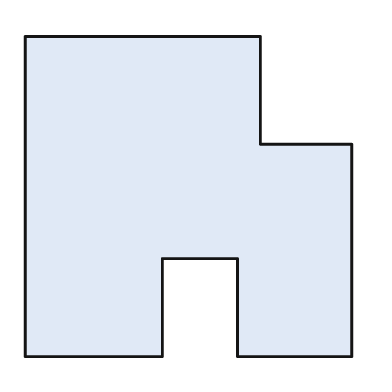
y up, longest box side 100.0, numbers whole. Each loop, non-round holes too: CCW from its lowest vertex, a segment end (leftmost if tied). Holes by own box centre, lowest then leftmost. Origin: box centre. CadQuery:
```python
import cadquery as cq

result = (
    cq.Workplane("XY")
    .moveTo(-50.0, -49.0)
    .lineTo(-8.0, -49.0)
    .lineTo(-8.0, -19.0)
    .lineTo(15.0, -19.0)
    .lineTo(15.0, -49.0)
    .lineTo(50.0, -49.0)
    .lineTo(50.0, 16.0)
    .lineTo(22.0, 16.0)
    .lineTo(22.0, 49.0)
    .lineTo(-50.0, 49.0)
    .close()
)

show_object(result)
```